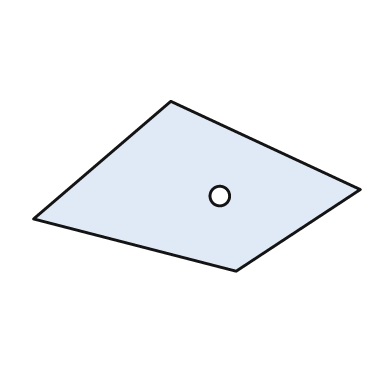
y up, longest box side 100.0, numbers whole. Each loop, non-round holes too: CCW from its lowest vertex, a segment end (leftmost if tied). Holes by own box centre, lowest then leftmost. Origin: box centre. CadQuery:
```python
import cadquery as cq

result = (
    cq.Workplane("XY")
    .moveTo(12.0, -26.0)
    .lineTo(50.0, -1.0)
    .lineTo(-8.0, 26.0)
    .lineTo(-50.0, -10.0)
    .close()
    .moveTo(7.0, -3.0)
    .circle(3.0)
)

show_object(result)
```